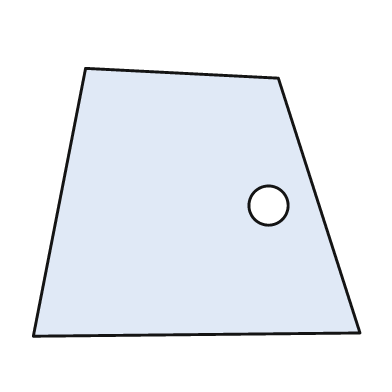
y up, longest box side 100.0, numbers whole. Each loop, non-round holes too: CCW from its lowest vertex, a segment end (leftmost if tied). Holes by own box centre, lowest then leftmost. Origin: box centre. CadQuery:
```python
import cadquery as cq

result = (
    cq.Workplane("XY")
    .moveTo(-50.0, -41.0)
    .lineTo(50.0, -40.0)
    .lineTo(25.0, 38.0)
    .lineTo(-34.0, 41.0)
    .close()
    .moveTo(22.0, -1.0)
    .circle(6.0)
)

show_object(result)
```